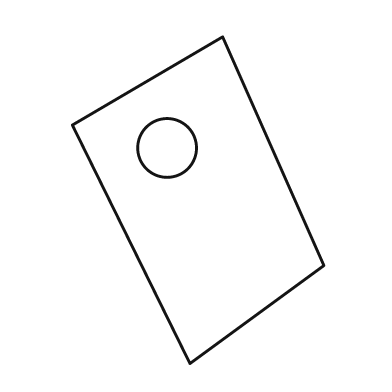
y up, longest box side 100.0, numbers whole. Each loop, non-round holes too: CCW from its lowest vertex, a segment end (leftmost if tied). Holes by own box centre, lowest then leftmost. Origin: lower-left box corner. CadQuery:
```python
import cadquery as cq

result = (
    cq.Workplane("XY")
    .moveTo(36.0, 0.0)
    .lineTo(77.0, 30.0)
    .lineTo(46.0, 100.0)
    .lineTo(0.0, 73.0)
    .close()
    .moveTo(29.0, 66.0)
    .circle(9.0)
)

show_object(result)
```